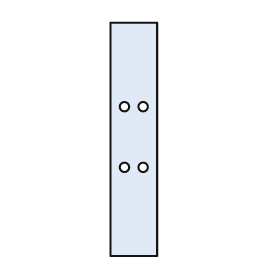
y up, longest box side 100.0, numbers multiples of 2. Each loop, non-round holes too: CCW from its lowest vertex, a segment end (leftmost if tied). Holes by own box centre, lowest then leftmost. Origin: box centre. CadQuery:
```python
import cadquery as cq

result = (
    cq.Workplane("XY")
    .moveTo(-10.0, -50.0)
    .lineTo(10.0, -50.0)
    .lineTo(10.0, 50.0)
    .lineTo(-10.0, 50.0)
    .close()
    .moveTo(-4.0, -12.0)
    .circle(2.0)
    .moveTo(4.0, -12.0)
    .circle(2.0)
    .moveTo(-4.0, 14.0)
    .circle(2.0)
    .moveTo(4.0, 14.0)
    .circle(2.0)
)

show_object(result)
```